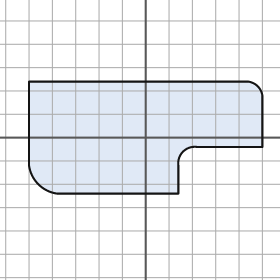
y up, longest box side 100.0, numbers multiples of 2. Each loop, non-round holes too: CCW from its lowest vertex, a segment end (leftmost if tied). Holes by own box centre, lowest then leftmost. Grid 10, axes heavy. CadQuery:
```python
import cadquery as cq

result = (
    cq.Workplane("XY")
    .moveTo(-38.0, -24.0)
    .lineTo(14.0, -24.0)
    .lineTo(14.0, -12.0)
    .threePointArc((16.0, -6.0), (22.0, -4.0))
    .lineTo(50.0, -4.0)
    .lineTo(50.0, 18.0)
    .threePointArc((48.0, 22.0), (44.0, 24.0))
    .lineTo(-50.0, 24.0)
    .lineTo(-50.0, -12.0)
    .threePointArc((-46.0, -20.0), (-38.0, -24.0))
    .close()
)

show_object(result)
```